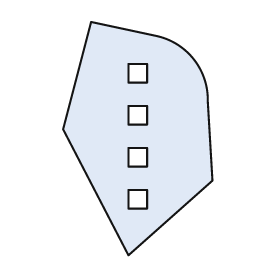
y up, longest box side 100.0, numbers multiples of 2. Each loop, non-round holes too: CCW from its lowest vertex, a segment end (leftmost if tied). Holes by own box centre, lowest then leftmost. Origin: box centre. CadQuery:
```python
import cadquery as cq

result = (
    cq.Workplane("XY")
    .moveTo(-4.0, -50.0)
    .lineTo(32.0, -18.0)
    .lineTo(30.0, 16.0)
    .threePointArc((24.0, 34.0), (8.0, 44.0))
    .lineTo(-20.0, 50.0)
    .lineTo(-32.0, 4.0)
    .close()
    .moveTo(-4.0, -30.0)
    .lineTo(4.0, -30.0)
    .lineTo(4.0, -22.0)
    .lineTo(-4.0, -22.0)
    .close()
    .moveTo(-4.0, -12.0)
    .lineTo(4.0, -12.0)
    .lineTo(4.0, -4.0)
    .lineTo(-4.0, -4.0)
    .close()
    .moveTo(-4.0, 6.0)
    .lineTo(4.0, 6.0)
    .lineTo(4.0, 14.0)
    .lineTo(-4.0, 14.0)
    .close()
    .moveTo(-4.0, 24.0)
    .lineTo(4.0, 24.0)
    .lineTo(4.0, 32.0)
    .lineTo(-4.0, 32.0)
    .close()
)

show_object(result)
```